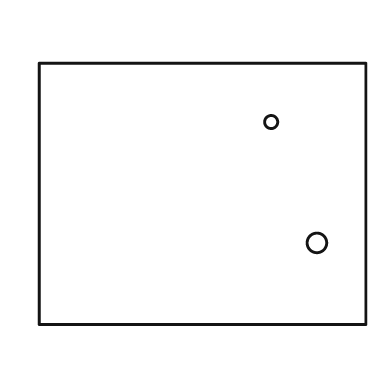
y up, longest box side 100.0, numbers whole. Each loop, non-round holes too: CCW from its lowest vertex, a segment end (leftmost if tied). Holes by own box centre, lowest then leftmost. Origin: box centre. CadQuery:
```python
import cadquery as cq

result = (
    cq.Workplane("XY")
    .moveTo(-50.0, -40.0)
    .lineTo(50.0, -40.0)
    .lineTo(50.0, 40.0)
    .lineTo(-50.0, 40.0)
    .close()
    .moveTo(35.0, -15.0)
    .circle(3.0)
    .moveTo(21.0, 22.0)
    .circle(2.0)
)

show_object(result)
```